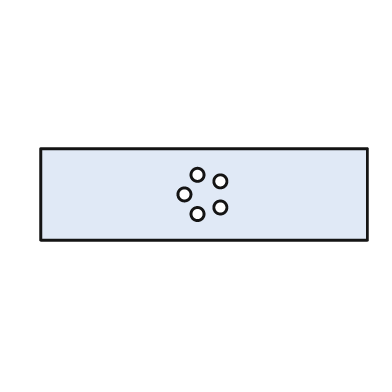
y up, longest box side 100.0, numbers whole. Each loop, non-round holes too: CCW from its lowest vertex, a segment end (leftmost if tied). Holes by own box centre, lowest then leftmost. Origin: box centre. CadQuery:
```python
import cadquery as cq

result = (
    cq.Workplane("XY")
    .moveTo(-50.0, -14.0)
    .lineTo(50.0, -14.0)
    .lineTo(50.0, 14.0)
    .lineTo(-50.0, 14.0)
    .close()
    .moveTo(-2.0, -6.0)
    .circle(2.0)
    .moveTo(5.0, -4.0)
    .circle(2.0)
    .moveTo(-6.0, 0.0)
    .circle(2.0)
    .moveTo(5.0, 4.0)
    .circle(2.0)
    .moveTo(-2.0, 6.0)
    .circle(2.0)
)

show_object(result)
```